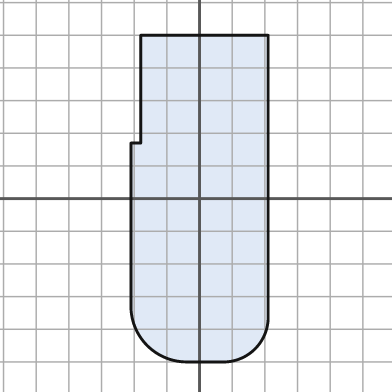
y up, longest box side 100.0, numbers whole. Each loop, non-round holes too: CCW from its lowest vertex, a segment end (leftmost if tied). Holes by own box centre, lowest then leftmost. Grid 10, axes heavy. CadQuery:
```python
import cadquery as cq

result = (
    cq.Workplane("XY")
    .moveTo(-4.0, -50.0)
    .lineTo(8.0, -50.0)
    .threePointArc((17.0, -46.0), (21.0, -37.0))
    .lineTo(21.0, 50.0)
    .lineTo(-18.0, 50.0)
    .lineTo(-18.0, 17.0)
    .lineTo(-21.0, 17.0)
    .lineTo(-21.0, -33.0)
    .threePointArc((-16.0, -45.0), (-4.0, -50.0))
    .close()
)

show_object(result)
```